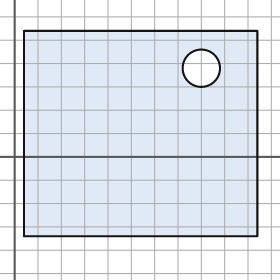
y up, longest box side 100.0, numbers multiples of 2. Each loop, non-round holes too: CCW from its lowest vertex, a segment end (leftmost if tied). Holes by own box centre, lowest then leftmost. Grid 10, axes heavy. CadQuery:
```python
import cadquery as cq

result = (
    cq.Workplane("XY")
    .moveTo(4.0, -34.0)
    .lineTo(104.0, -34.0)
    .lineTo(104.0, 54.0)
    .lineTo(4.0, 54.0)
    .close()
    .moveTo(80.0, 38.0)
    .circle(8.0)
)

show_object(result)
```